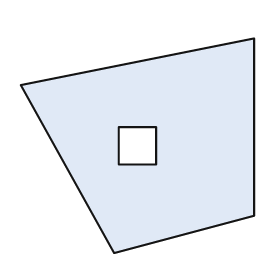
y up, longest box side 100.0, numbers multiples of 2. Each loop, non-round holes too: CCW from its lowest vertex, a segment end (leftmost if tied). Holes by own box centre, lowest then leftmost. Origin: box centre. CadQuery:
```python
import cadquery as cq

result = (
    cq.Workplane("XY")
    .moveTo(-10.0, -46.0)
    .lineTo(50.0, -30.0)
    .lineTo(50.0, 46.0)
    .lineTo(-50.0, 26.0)
    .close()
    .moveTo(-8.0, -8.0)
    .lineTo(8.0, -8.0)
    .lineTo(8.0, 8.0)
    .lineTo(-8.0, 8.0)
    .close()
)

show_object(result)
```